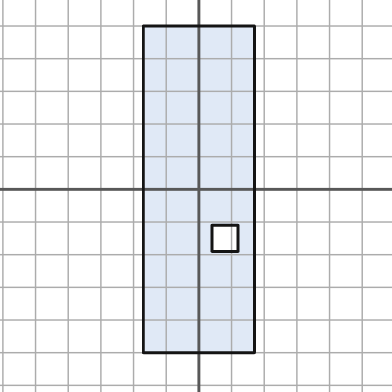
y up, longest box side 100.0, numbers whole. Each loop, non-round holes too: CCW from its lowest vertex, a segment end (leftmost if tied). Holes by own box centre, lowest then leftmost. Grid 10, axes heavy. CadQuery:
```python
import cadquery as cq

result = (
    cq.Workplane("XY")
    .moveTo(-17.0, -50.0)
    .lineTo(17.0, -50.0)
    .lineTo(17.0, 50.0)
    .lineTo(-17.0, 50.0)
    .close()
    .moveTo(4.0, -19.0)
    .lineTo(12.0, -19.0)
    .lineTo(12.0, -11.0)
    .lineTo(4.0, -11.0)
    .close()
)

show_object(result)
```